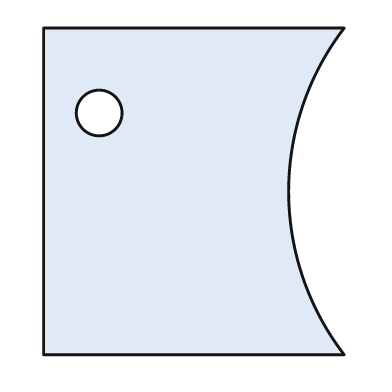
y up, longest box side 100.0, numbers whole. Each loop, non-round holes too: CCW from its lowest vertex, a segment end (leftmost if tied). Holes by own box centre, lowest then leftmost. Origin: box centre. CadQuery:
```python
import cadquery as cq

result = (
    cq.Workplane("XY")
    .moveTo(-46.0, -50.0)
    .lineTo(46.0, -50.0)
    .threePointArc((29.0, 0.0), (46.0, 50.0))
    .lineTo(-46.0, 50.0)
    .close()
    .moveTo(-29.0, 24.0)
    .circle(7.0)
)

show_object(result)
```